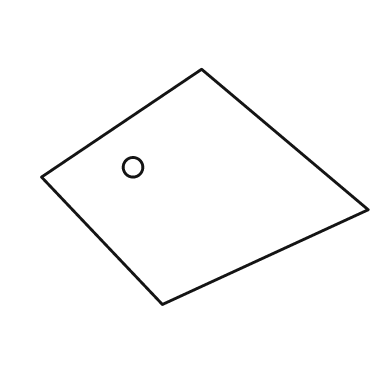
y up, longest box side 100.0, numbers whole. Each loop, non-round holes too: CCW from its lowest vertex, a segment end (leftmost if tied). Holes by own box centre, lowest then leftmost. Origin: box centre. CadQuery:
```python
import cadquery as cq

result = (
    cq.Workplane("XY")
    .moveTo(-13.0, -36.0)
    .lineTo(50.0, -7.0)
    .lineTo(-1.0, 36.0)
    .lineTo(-50.0, 3.0)
    .close()
    .moveTo(-22.0, 6.0)
    .circle(3.0)
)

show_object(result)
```